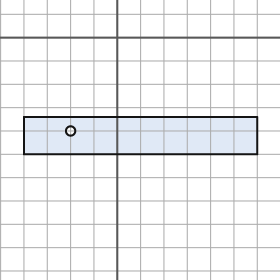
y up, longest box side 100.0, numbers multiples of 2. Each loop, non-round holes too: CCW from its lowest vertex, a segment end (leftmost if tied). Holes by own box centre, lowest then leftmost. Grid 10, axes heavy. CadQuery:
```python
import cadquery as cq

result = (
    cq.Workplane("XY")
    .moveTo(-40.0, -50.0)
    .lineTo(60.0, -50.0)
    .lineTo(60.0, -34.0)
    .lineTo(-40.0, -34.0)
    .close()
    .moveTo(-20.0, -40.0)
    .circle(2.0)
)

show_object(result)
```